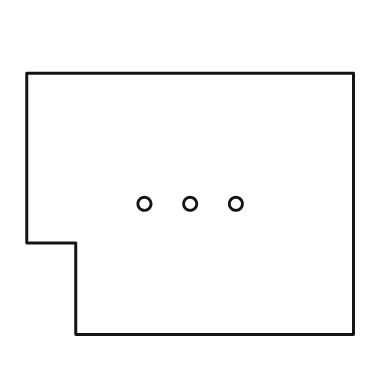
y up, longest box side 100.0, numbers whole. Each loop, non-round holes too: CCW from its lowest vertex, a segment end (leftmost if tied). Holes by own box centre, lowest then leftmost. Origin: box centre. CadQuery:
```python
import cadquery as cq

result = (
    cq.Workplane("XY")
    .moveTo(-35.0, -40.0)
    .lineTo(50.0, -40.0)
    .lineTo(50.0, 40.0)
    .lineTo(-50.0, 40.0)
    .lineTo(-50.0, -12.0)
    .lineTo(-35.0, -12.0)
    .close()
    .moveTo(-14.0, 0.0)
    .circle(2.0)
    .moveTo(0.0, 0.0)
    .circle(2.0)
    .moveTo(14.0, 0.0)
    .circle(2.0)
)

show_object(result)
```